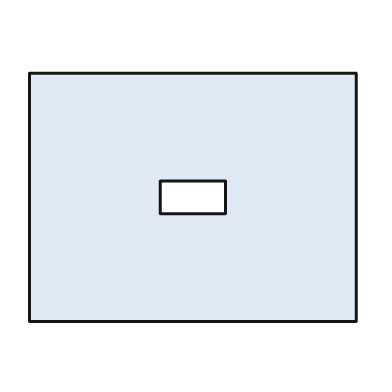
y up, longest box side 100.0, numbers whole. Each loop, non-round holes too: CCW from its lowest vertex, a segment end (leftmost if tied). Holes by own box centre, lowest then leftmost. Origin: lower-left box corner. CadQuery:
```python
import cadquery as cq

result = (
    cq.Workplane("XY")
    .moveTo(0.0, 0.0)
    .lineTo(100.0, 0.0)
    .lineTo(100.0, 76.0)
    .lineTo(0.0, 76.0)
    .close()
    .moveTo(40.0, 33.0)
    .lineTo(60.0, 33.0)
    .lineTo(60.0, 43.0)
    .lineTo(40.0, 43.0)
    .close()
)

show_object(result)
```